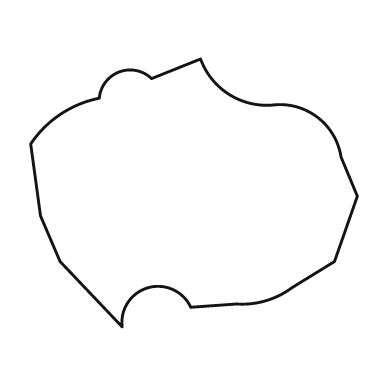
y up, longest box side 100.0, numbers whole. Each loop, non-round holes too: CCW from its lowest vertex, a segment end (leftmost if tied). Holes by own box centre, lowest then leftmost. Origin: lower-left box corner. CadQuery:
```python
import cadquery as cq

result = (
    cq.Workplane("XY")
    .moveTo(28.0, 0.0)
    .threePointArc((36.0, 12.0), (49.0, 6.0))
    .lineTo(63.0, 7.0)
    .threePointArc((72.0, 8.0), (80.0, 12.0))
    .lineTo(93.0, 20.0)
    .lineTo(100.0, 40.0)
    .lineTo(95.0, 52.0)
    .threePointArc((88.0, 64.0), (75.0, 68.0))
    .threePointArc((61.0, 71.0), (52.0, 82.0))
    .lineTo(37.0, 76.0)
    .threePointArc((27.0, 78.0), (21.0, 70.0))
    .threePointArc((9.0, 65.0), (0.0, 56.0))
    .lineTo(3.0, 34.0)
    .lineTo(9.0, 20.0)
    .close()
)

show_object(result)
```